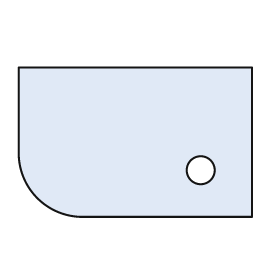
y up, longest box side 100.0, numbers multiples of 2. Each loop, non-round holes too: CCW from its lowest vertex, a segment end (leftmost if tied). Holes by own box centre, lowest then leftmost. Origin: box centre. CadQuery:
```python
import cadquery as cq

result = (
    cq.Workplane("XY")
    .moveTo(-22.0, -32.0)
    .lineTo(50.0, -32.0)
    .lineTo(50.0, 32.0)
    .lineTo(-50.0, 32.0)
    .lineTo(-50.0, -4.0)
    .threePointArc((-42.0, -24.0), (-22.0, -32.0))
    .close()
    .moveTo(28.0, -12.0)
    .circle(6.0)
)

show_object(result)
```